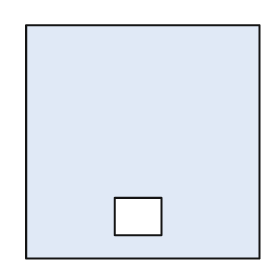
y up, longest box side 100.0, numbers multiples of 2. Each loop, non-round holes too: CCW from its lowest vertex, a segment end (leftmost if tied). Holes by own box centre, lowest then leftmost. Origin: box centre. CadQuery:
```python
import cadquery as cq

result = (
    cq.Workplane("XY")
    .moveTo(-50.0, -50.0)
    .lineTo(50.0, -50.0)
    .lineTo(50.0, 50.0)
    .lineTo(-50.0, 50.0)
    .close()
    .moveTo(-12.0, -40.0)
    .lineTo(8.0, -40.0)
    .lineTo(8.0, -24.0)
    .lineTo(-12.0, -24.0)
    .close()
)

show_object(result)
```